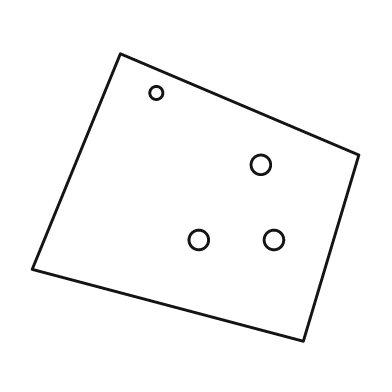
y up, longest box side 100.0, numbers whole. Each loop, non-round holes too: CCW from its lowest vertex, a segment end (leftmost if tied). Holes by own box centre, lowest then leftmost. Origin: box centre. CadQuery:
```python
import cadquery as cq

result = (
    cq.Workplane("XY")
    .moveTo(33.0, -44.0)
    .lineTo(50.0, 13.0)
    .lineTo(-23.0, 44.0)
    .lineTo(-50.0, -22.0)
    .close()
    .moveTo(1.0, -13.0)
    .circle(3.0)
    .moveTo(24.0, -13.0)
    .circle(3.0)
    .moveTo(20.0, 10.0)
    .circle(3.0)
    .moveTo(-12.0, 32.0)
    .circle(2.0)
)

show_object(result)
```